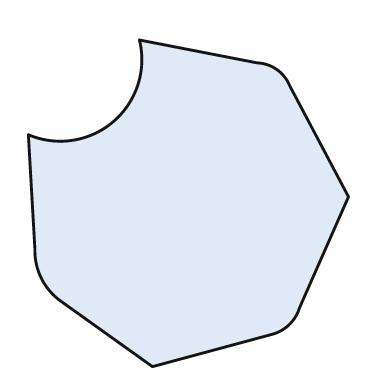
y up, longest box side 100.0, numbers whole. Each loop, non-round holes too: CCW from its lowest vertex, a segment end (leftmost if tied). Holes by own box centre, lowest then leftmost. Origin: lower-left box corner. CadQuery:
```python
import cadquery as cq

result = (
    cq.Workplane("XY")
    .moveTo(38.0, 0.0)
    .lineTo(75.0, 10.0)
    .threePointArc((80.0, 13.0), (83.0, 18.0))
    .lineTo(98.0, 52.0)
    .lineTo(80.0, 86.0)
    .threePointArc((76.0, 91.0), (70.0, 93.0))
    .lineTo(34.0, 100.0)
    .threePointArc((26.0, 75.0), (0.0, 71.0))
    .lineTo(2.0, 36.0)
    .threePointArc((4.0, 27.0), (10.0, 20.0))
    .close()
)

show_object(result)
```